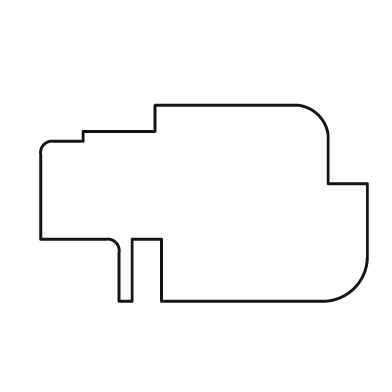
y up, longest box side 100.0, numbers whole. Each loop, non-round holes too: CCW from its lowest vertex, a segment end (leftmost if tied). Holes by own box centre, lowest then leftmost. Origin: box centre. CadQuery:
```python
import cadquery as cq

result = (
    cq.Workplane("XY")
    .moveTo(-26.0, -30.0)
    .lineTo(-22.0, -30.0)
    .lineTo(-22.0, -11.0)
    .lineTo(-13.0, -11.0)
    .lineTo(-13.0, -30.0)
    .lineTo(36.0, -30.0)
    .threePointArc((46.0, -26.0), (50.0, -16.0))
    .lineTo(50.0, 6.0)
    .lineTo(38.0, 6.0)
    .lineTo(38.0, 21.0)
    .threePointArc((35.0, 27.0), (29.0, 30.0))
    .lineTo(-15.0, 30.0)
    .lineTo(-15.0, 22.0)
    .lineTo(-37.0, 22.0)
    .lineTo(-37.0, 19.0)
    .lineTo(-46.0, 19.0)
    .threePointArc((-49.0, 18.0), (-50.0, 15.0))
    .lineTo(-50.0, -11.0)
    .lineTo(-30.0, -11.0)
    .threePointArc((-27.0, -12.0), (-26.0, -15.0))
    .close()
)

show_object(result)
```